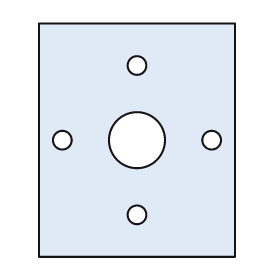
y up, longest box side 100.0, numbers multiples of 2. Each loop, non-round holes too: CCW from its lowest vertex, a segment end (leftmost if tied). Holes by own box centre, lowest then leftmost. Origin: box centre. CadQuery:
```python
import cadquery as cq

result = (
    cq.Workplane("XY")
    .moveTo(-42.0, -50.0)
    .lineTo(42.0, -50.0)
    .lineTo(42.0, 50.0)
    .lineTo(-42.0, 50.0)
    .close()
    .moveTo(0.0, -32.0)
    .circle(4.0)
    .moveTo(-32.0, 0.0)
    .circle(4.0)
    .moveTo(0.0, 0.0)
    .circle(12.0)
    .moveTo(32.0, 0.0)
    .circle(4.0)
    .moveTo(0.0, 32.0)
    .circle(4.0)
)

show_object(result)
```